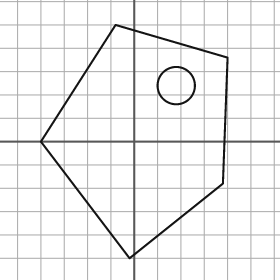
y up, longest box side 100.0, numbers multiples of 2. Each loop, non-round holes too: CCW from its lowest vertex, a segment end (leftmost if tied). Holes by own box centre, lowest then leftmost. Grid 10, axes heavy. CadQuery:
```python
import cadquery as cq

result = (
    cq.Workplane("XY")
    .moveTo(-2.0, -50.0)
    .lineTo(38.0, -18.0)
    .lineTo(40.0, 36.0)
    .lineTo(-8.0, 50.0)
    .lineTo(-40.0, 0.0)
    .close()
    .moveTo(18.0, 24.0)
    .circle(8.0)
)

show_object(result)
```